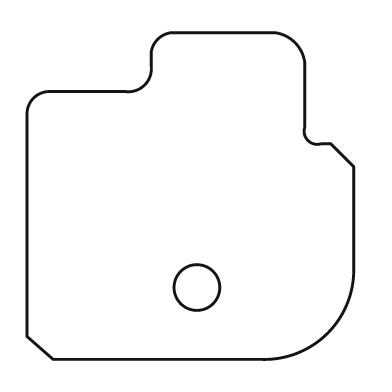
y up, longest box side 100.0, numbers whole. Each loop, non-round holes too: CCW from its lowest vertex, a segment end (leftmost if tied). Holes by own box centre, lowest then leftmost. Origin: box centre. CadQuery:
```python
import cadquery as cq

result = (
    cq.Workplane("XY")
    .moveTo(-42.0, -50.0)
    .lineTo(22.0, -50.0)
    .threePointArc((42.0, -42.0), (50.0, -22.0))
    .lineTo(50.0, 9.0)
    .lineTo(43.0, 16.0)
    .lineTo(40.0, 16.0)
    .threePointArc((36.0, 17.0), (35.0, 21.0))
    .lineTo(35.0, 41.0)
    .threePointArc((32.0, 47.0), (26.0, 50.0))
    .lineTo(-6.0, 50.0)
    .threePointArc((-10.0, 48.0), (-12.0, 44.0))
    .lineTo(-12.0, 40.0)
    .threePointArc((-14.0, 34.0), (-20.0, 32.0))
    .lineTo(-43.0, 32.0)
    .threePointArc((-48.0, 30.0), (-50.0, 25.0))
    .lineTo(-50.0, -43.0)
    .close()
    .moveTo(2.0, -28.0)
    .circle(7.0)
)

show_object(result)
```